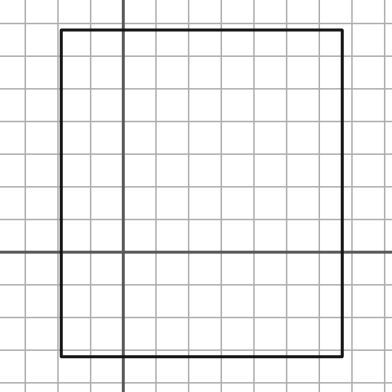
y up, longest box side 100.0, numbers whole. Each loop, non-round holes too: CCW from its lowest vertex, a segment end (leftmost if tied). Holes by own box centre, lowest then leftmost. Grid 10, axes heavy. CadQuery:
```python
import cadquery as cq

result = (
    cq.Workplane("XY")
    .moveTo(-19.0, -32.0)
    .lineTo(67.0, -32.0)
    .lineTo(67.0, 68.0)
    .lineTo(-19.0, 68.0)
    .close()
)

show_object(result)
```